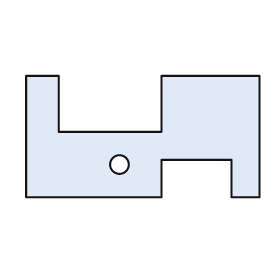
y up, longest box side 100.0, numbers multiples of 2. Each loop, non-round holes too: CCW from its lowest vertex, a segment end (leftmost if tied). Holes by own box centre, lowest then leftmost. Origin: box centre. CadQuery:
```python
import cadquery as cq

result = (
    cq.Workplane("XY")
    .moveTo(-50.0, -26.0)
    .lineTo(8.0, -26.0)
    .lineTo(8.0, -10.0)
    .lineTo(38.0, -10.0)
    .lineTo(38.0, -26.0)
    .lineTo(50.0, -26.0)
    .lineTo(50.0, 26.0)
    .lineTo(8.0, 26.0)
    .lineTo(8.0, 2.0)
    .lineTo(-36.0, 2.0)
    .lineTo(-36.0, 26.0)
    .lineTo(-50.0, 26.0)
    .close()
    .moveTo(-10.0, -12.0)
    .circle(4.0)
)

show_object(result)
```